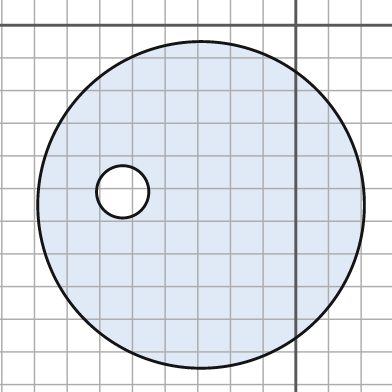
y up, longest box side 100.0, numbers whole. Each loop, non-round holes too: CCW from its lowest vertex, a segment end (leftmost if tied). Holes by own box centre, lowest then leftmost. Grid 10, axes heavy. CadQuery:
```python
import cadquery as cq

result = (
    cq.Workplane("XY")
    .moveTo(-29.0, -55.0)
    .circle(50.0)
    .moveTo(-53.0, -51.0)
    .circle(8.0)
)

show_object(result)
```